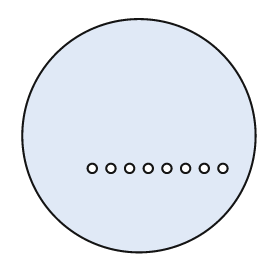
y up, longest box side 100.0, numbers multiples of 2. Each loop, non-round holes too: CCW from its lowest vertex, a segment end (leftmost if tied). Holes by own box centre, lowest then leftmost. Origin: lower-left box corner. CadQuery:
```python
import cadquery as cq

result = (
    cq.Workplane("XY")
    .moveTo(50.0, 50.0)
    .circle(50.0)
    .moveTo(30.0, 36.0)
    .circle(2.0)
    .moveTo(38.0, 36.0)
    .circle(2.0)
    .moveTo(46.0, 36.0)
    .circle(2.0)
    .moveTo(54.0, 36.0)
    .circle(2.0)
    .moveTo(62.0, 36.0)
    .circle(2.0)
    .moveTo(70.0, 36.0)
    .circle(2.0)
    .moveTo(78.0, 36.0)
    .circle(2.0)
    .moveTo(86.0, 36.0)
    .circle(2.0)
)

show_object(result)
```